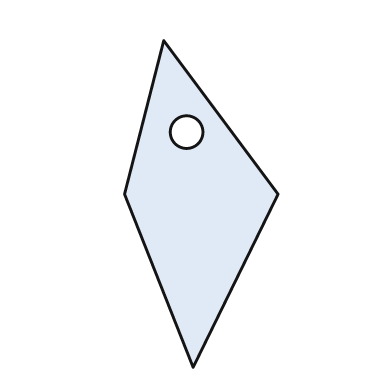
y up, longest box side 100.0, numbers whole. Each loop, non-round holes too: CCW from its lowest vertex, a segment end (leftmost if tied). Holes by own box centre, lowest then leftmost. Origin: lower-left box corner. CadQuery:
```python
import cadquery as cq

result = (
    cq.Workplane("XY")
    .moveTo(21.0, 0.0)
    .lineTo(47.0, 53.0)
    .lineTo(12.0, 100.0)
    .lineTo(0.0, 53.0)
    .close()
    .moveTo(19.0, 72.0)
    .circle(5.0)
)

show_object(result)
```